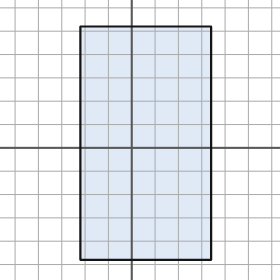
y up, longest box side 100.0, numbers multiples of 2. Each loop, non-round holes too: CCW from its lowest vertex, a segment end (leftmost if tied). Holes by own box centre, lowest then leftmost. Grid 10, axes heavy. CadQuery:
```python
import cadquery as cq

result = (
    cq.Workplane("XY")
    .moveTo(-22.0, -48.0)
    .lineTo(34.0, -48.0)
    .lineTo(34.0, 52.0)
    .lineTo(-22.0, 52.0)
    .close()
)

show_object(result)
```